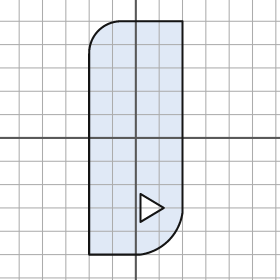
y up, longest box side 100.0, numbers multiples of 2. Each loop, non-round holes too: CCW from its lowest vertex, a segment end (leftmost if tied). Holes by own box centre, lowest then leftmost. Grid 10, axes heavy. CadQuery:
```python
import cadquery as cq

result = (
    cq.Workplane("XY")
    .moveTo(-20.0, -50.0)
    .lineTo(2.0, -50.0)
    .threePointArc((14.0, -44.0), (20.0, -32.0))
    .lineTo(20.0, 50.0)
    .lineTo(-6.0, 50.0)
    .threePointArc((-16.0, 46.0), (-20.0, 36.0))
    .close()
    .moveTo(2.0, -36.0)
    .lineTo(12.0, -30.0)
    .lineTo(2.0, -24.0)
    .close()
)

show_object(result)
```